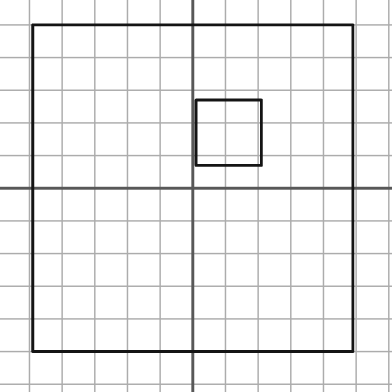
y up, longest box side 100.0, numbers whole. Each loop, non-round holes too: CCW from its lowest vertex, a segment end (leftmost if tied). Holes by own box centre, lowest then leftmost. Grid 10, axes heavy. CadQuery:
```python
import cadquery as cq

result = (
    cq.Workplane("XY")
    .moveTo(-49.0, -50.0)
    .lineTo(49.0, -50.0)
    .lineTo(49.0, 50.0)
    .lineTo(-49.0, 50.0)
    .close()
    .moveTo(1.0, 7.0)
    .lineTo(21.0, 7.0)
    .lineTo(21.0, 27.0)
    .lineTo(1.0, 27.0)
    .close()
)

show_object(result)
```